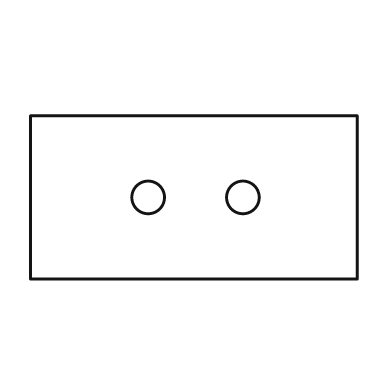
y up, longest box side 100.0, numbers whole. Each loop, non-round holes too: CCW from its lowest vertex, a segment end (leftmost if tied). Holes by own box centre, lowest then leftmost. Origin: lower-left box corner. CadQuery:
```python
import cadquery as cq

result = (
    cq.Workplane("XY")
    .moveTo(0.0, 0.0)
    .lineTo(100.0, 0.0)
    .lineTo(100.0, 50.0)
    .lineTo(0.0, 50.0)
    .close()
    .moveTo(36.0, 25.0)
    .circle(5.0)
    .moveTo(65.0, 25.0)
    .circle(5.0)
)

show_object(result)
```